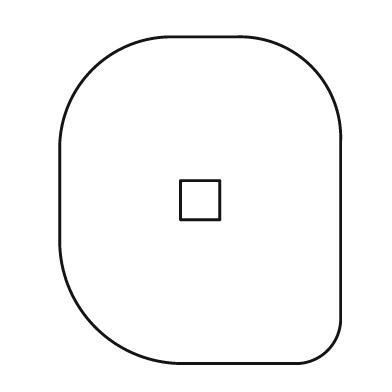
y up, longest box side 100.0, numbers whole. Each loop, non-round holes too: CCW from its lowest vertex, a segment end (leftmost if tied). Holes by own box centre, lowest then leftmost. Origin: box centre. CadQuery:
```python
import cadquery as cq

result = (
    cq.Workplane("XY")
    .moveTo(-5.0, -50.0)
    .lineTo(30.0, -50.0)
    .threePointArc((39.0, -46.0), (43.0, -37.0))
    .lineTo(43.0, 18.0)
    .threePointArc((34.0, 41.0), (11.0, 50.0))
    .lineTo(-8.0, 50.0)
    .threePointArc((-33.0, 40.0), (-43.0, 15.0))
    .lineTo(-43.0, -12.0)
    .threePointArc((-32.0, -39.0), (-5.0, -50.0))
    .close()
    .moveTo(-6.0, -6.0)
    .lineTo(6.0, -6.0)
    .lineTo(6.0, 6.0)
    .lineTo(-6.0, 6.0)
    .close()
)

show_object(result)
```